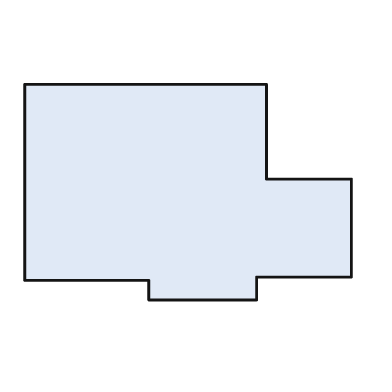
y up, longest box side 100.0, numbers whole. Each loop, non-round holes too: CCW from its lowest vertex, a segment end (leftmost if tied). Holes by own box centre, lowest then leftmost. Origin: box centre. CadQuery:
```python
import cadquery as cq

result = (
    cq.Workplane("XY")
    .moveTo(-12.0, -33.0)
    .lineTo(21.0, -33.0)
    .lineTo(21.0, -26.0)
    .lineTo(50.0, -26.0)
    .lineTo(50.0, 4.0)
    .lineTo(24.0, 4.0)
    .lineTo(24.0, 33.0)
    .lineTo(-50.0, 33.0)
    .lineTo(-50.0, -27.0)
    .lineTo(-12.0, -27.0)
    .close()
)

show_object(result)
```